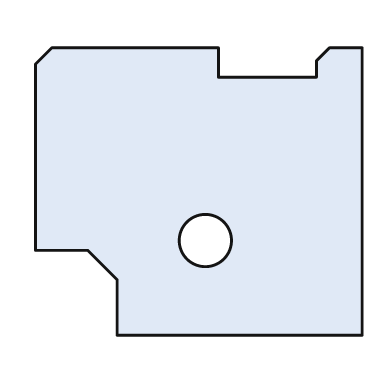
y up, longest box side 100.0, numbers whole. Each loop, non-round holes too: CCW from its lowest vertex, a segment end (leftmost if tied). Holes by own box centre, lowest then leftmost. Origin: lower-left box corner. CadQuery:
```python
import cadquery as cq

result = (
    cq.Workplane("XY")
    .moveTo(25.0, 0.0)
    .lineTo(100.0, 0.0)
    .lineTo(100.0, 88.0)
    .lineTo(90.0, 88.0)
    .lineTo(86.0, 84.0)
    .lineTo(86.0, 79.0)
    .lineTo(56.0, 79.0)
    .lineTo(56.0, 88.0)
    .lineTo(5.0, 88.0)
    .lineTo(0.0, 83.0)
    .lineTo(0.0, 26.0)
    .lineTo(16.0, 26.0)
    .lineTo(25.0, 17.0)
    .close()
    .moveTo(52.0, 29.0)
    .circle(8.0)
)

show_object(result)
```